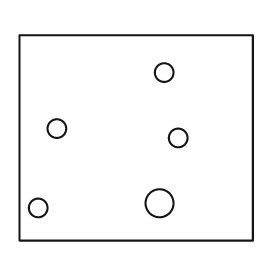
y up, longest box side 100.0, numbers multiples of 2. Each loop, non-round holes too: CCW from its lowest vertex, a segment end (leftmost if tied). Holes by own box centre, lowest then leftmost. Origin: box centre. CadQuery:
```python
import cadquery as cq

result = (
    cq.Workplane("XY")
    .moveTo(-50.0, -44.0)
    .lineTo(50.0, -44.0)
    .lineTo(50.0, 44.0)
    .lineTo(-50.0, 44.0)
    .close()
    .moveTo(-42.0, -30.0)
    .circle(4.0)
    .moveTo(10.0, -28.0)
    .circle(6.0)
    .moveTo(18.0, 0.0)
    .circle(4.0)
    .moveTo(-34.0, 4.0)
    .circle(4.0)
    .moveTo(12.0, 28.0)
    .circle(4.0)
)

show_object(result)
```